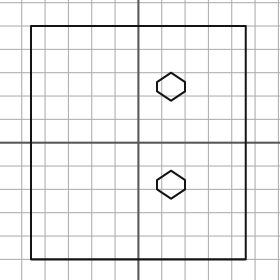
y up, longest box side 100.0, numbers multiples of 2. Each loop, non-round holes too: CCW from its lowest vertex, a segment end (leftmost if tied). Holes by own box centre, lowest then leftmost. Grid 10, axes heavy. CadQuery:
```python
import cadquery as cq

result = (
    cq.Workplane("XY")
    .moveTo(-46.0, -50.0)
    .lineTo(46.0, -50.0)
    .lineTo(46.0, 50.0)
    .lineTo(-46.0, 50.0)
    .close()
    .moveTo(14.0, -24.0)
    .lineTo(20.0, -20.0)
    .lineTo(20.0, -16.0)
    .lineTo(14.0, -12.0)
    .lineTo(8.0, -16.0)
    .lineTo(8.0, -20.0)
    .close()
    .moveTo(14.0, 18.0)
    .lineTo(20.0, 22.0)
    .lineTo(20.0, 26.0)
    .lineTo(14.0, 30.0)
    .lineTo(8.0, 26.0)
    .lineTo(8.0, 22.0)
    .close()
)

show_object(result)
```